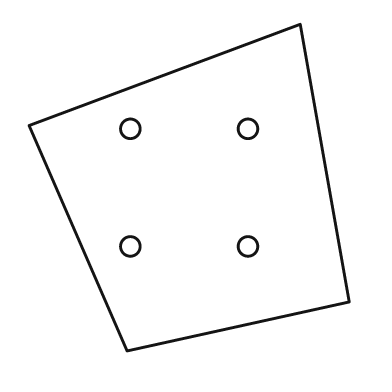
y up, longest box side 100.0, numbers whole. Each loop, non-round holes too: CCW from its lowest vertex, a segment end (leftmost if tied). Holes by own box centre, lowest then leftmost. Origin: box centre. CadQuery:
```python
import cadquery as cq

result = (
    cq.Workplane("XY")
    .moveTo(-19.0, -50.0)
    .lineTo(49.0, -35.0)
    .lineTo(34.0, 50.0)
    .lineTo(-49.0, 19.0)
    .close()
    .moveTo(-18.0, -18.0)
    .circle(3.0)
    .moveTo(18.0, -18.0)
    .circle(3.0)
    .moveTo(-18.0, 18.0)
    .circle(3.0)
    .moveTo(18.0, 18.0)
    .circle(3.0)
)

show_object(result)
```